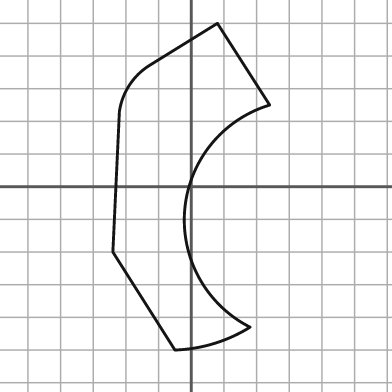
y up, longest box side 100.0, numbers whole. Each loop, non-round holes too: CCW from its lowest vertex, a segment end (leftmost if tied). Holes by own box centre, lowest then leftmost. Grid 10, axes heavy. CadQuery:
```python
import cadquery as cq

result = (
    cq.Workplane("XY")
    .moveTo(-5.0, -50.0)
    .threePointArc((7.0, -48.0), (18.0, -43.0))
    .threePointArc((-2.0, -7.0), (24.0, 25.0))
    .lineTo(8.0, 50.0)
    .lineTo(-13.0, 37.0)
    .threePointArc((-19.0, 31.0), (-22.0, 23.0))
    .lineTo(-24.0, -20.0)
    .close()
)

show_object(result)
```